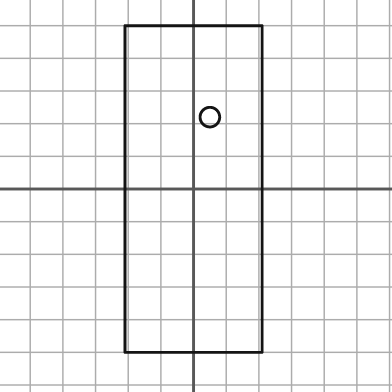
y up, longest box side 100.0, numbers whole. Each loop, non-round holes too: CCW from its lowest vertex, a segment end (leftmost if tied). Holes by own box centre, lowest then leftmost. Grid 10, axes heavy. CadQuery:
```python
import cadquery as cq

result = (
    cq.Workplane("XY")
    .moveTo(-21.0, -50.0)
    .lineTo(21.0, -50.0)
    .lineTo(21.0, 50.0)
    .lineTo(-21.0, 50.0)
    .close()
    .moveTo(5.0, 22.0)
    .circle(3.0)
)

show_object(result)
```